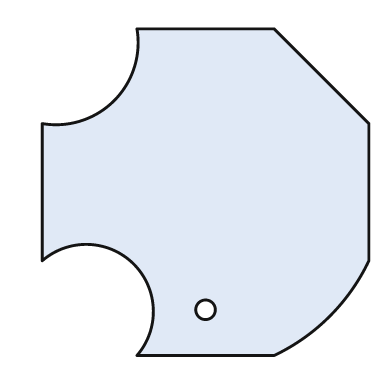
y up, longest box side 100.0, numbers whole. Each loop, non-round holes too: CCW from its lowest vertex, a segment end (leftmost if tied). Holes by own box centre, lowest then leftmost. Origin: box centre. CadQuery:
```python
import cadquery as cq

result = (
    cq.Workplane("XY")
    .moveTo(-21.0, -50.0)
    .lineTo(21.0, -50.0)
    .threePointArc((38.0, -38.0), (50.0, -21.0))
    .lineTo(50.0, 21.0)
    .lineTo(21.0, 50.0)
    .lineTo(-21.0, 50.0)
    .threePointArc((-28.0, 28.0), (-50.0, 21.0))
    .lineTo(-50.0, -21.0)
    .threePointArc((-22.0, -22.0), (-21.0, -50.0))
    .close()
    .moveTo(0.0, -36.0)
    .circle(3.0)
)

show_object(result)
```